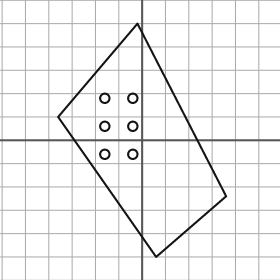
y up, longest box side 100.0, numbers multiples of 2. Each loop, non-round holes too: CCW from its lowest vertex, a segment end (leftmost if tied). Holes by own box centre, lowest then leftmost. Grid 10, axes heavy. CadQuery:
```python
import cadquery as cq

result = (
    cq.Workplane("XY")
    .moveTo(6.0, -50.0)
    .lineTo(36.0, -24.0)
    .lineTo(-2.0, 50.0)
    .lineTo(-36.0, 10.0)
    .close()
    .moveTo(-16.0, -6.0)
    .circle(2.0)
    .moveTo(-4.0, -6.0)
    .circle(2.0)
    .moveTo(-16.0, 6.0)
    .circle(2.0)
    .moveTo(-4.0, 6.0)
    .circle(2.0)
    .moveTo(-16.0, 18.0)
    .circle(2.0)
    .moveTo(-4.0, 18.0)
    .circle(2.0)
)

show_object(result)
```